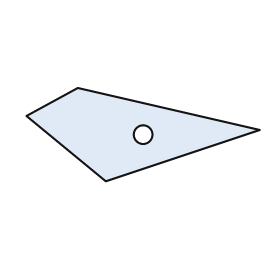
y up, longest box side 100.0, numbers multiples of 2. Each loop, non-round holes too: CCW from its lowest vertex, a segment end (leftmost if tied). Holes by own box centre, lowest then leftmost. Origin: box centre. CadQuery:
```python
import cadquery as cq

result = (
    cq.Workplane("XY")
    .moveTo(-16.0, -20.0)
    .lineTo(50.0, 2.0)
    .lineTo(-28.0, 20.0)
    .lineTo(-50.0, 8.0)
    .close()
    .moveTo(0.0, 0.0)
    .circle(4.0)
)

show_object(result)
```